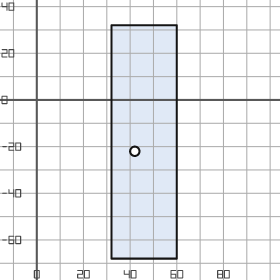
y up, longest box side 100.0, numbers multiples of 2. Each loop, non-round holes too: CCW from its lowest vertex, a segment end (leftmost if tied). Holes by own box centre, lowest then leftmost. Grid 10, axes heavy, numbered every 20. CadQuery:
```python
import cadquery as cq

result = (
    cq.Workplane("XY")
    .moveTo(32.0, -68.0)
    .lineTo(60.0, -68.0)
    .lineTo(60.0, 32.0)
    .lineTo(32.0, 32.0)
    .close()
    .moveTo(42.0, -22.0)
    .circle(2.0)
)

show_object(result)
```